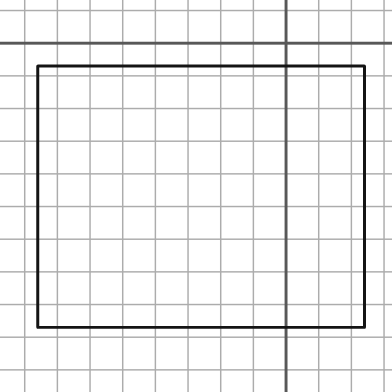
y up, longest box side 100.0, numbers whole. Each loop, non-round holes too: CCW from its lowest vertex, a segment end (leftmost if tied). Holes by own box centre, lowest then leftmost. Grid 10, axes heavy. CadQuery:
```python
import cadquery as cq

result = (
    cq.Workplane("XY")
    .moveTo(-76.0, -87.0)
    .lineTo(24.0, -87.0)
    .lineTo(24.0, -7.0)
    .lineTo(-76.0, -7.0)
    .close()
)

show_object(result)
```